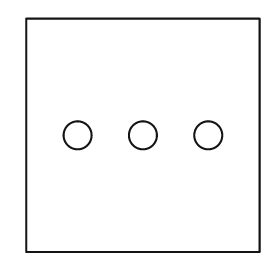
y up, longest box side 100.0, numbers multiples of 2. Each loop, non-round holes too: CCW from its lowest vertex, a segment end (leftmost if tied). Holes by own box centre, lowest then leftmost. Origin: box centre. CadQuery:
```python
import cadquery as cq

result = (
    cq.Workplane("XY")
    .moveTo(-50.0, -50.0)
    .lineTo(50.0, -50.0)
    .lineTo(50.0, 50.0)
    .lineTo(-50.0, 50.0)
    .close()
    .moveTo(-28.0, 0.0)
    .circle(6.0)
    .moveTo(0.0, 0.0)
    .circle(6.0)
    .moveTo(28.0, 0.0)
    .circle(6.0)
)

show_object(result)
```